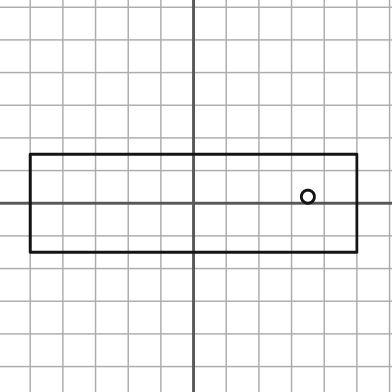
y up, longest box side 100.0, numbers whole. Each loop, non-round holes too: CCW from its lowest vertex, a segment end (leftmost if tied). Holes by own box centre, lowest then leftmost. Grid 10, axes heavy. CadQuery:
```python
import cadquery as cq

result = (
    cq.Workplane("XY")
    .moveTo(-50.0, -15.0)
    .lineTo(50.0, -15.0)
    .lineTo(50.0, 15.0)
    .lineTo(-50.0, 15.0)
    .close()
    .moveTo(35.0, 2.0)
    .circle(2.0)
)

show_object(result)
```